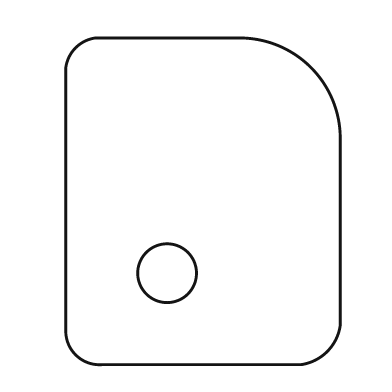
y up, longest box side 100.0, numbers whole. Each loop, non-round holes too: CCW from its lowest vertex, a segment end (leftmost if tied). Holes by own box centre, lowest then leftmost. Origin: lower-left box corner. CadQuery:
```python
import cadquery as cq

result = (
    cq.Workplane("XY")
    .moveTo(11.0, 0.0)
    .lineTo(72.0, 0.0)
    .threePointArc((80.0, 4.0), (84.0, 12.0))
    .lineTo(84.0, 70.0)
    .threePointArc((75.0, 91.0), (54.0, 100.0))
    .lineTo(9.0, 100.0)
    .threePointArc((3.0, 97.0), (0.0, 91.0))
    .lineTo(0.0, 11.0)
    .threePointArc((3.0, 3.0), (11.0, 0.0))
    .close()
    .moveTo(31.0, 28.0)
    .circle(9.0)
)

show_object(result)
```